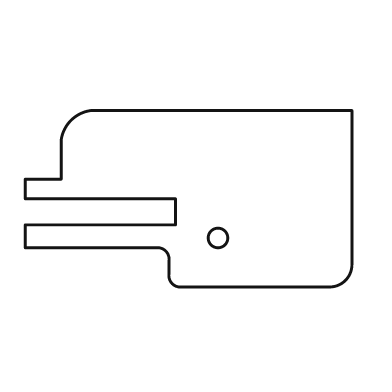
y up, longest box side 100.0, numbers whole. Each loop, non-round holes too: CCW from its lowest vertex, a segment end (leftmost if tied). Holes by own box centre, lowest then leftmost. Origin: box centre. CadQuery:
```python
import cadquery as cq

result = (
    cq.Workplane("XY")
    .moveTo(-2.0, -27.0)
    .lineTo(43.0, -27.0)
    .threePointArc((48.0, -25.0), (50.0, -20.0))
    .lineTo(50.0, 27.0)
    .lineTo(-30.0, 27.0)
    .threePointArc((-36.0, 24.0), (-39.0, 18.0))
    .lineTo(-39.0, 6.0)
    .lineTo(-50.0, 6.0)
    .lineTo(-50.0, 0.0)
    .lineTo(-4.0, 0.0)
    .lineTo(-4.0, -8.0)
    .lineTo(-50.0, -8.0)
    .lineTo(-50.0, -15.0)
    .lineTo(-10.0, -15.0)
    .threePointArc((-7.0, -16.0), (-6.0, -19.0))
    .lineTo(-6.0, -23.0)
    .threePointArc((-5.0, -26.0), (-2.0, -27.0))
    .close()
    .moveTo(9.0, -12.0)
    .circle(3.0)
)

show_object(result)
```